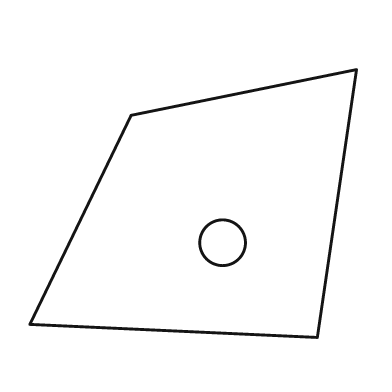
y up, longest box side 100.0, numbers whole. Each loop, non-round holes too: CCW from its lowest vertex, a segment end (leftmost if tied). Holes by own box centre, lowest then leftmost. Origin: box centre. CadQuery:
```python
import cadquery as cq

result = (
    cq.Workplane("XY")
    .moveTo(38.0, -41.0)
    .lineTo(50.0, 41.0)
    .lineTo(-19.0, 27.0)
    .lineTo(-50.0, -37.0)
    .close()
    .moveTo(9.0, -12.0)
    .circle(7.0)
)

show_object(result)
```